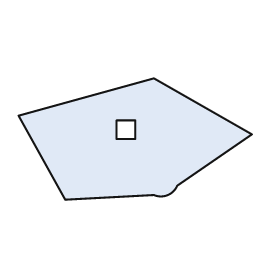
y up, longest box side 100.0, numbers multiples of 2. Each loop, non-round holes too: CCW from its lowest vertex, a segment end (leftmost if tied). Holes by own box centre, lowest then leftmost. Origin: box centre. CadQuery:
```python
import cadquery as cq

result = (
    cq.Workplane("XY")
    .moveTo(-30.0, -26.0)
    .lineTo(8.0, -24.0)
    .threePointArc((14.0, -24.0), (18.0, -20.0))
    .lineTo(50.0, 2.0)
    .lineTo(8.0, 26.0)
    .lineTo(-50.0, 10.0)
    .close()
    .moveTo(-8.0, 0.0)
    .lineTo(0.0, 0.0)
    .lineTo(0.0, 8.0)
    .lineTo(-8.0, 8.0)
    .close()
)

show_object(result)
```